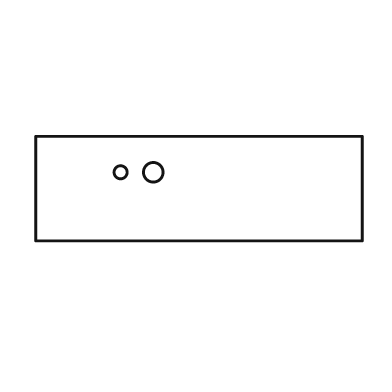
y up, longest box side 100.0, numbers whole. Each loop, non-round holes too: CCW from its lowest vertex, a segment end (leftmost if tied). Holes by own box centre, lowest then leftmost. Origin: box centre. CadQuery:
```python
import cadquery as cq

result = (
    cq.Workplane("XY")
    .moveTo(-50.0, -16.0)
    .lineTo(50.0, -16.0)
    .lineTo(50.0, 16.0)
    .lineTo(-50.0, 16.0)
    .close()
    .moveTo(-24.0, 5.0)
    .circle(2.0)
    .moveTo(-14.0, 5.0)
    .circle(3.0)
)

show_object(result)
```